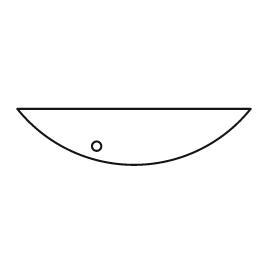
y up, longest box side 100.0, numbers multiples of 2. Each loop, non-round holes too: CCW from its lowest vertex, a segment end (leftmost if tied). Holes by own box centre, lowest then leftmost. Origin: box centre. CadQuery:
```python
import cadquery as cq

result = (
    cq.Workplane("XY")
    .moveTo(-50.0, 12.0)
    .threePointArc((0.0, -12.0), (50.0, 12.0))
    .close()
    .moveTo(-16.0, -4.0)
    .circle(2.0)
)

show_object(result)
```